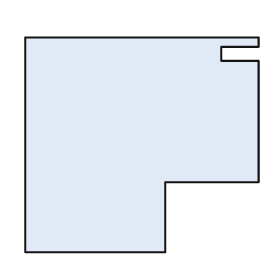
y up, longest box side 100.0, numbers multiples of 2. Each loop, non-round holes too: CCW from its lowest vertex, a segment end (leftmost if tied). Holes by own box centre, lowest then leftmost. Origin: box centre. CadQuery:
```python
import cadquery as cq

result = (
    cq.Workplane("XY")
    .moveTo(-50.0, -46.0)
    .lineTo(10.0, -46.0)
    .lineTo(10.0, -16.0)
    .lineTo(50.0, -16.0)
    .lineTo(50.0, 36.0)
    .lineTo(34.0, 36.0)
    .lineTo(34.0, 42.0)
    .lineTo(50.0, 42.0)
    .lineTo(50.0, 46.0)
    .lineTo(-50.0, 46.0)
    .close()
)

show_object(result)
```